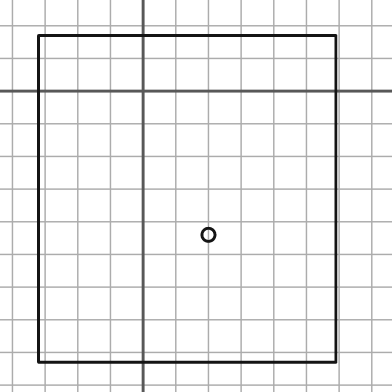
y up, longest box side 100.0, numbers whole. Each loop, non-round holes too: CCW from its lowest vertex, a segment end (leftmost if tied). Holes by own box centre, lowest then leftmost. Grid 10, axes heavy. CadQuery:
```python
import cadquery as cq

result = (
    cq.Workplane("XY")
    .moveTo(-32.0, -83.0)
    .lineTo(59.0, -83.0)
    .lineTo(59.0, 17.0)
    .lineTo(-32.0, 17.0)
    .close()
    .moveTo(20.0, -44.0)
    .circle(2.0)
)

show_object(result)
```